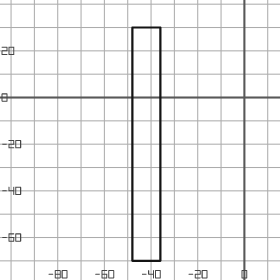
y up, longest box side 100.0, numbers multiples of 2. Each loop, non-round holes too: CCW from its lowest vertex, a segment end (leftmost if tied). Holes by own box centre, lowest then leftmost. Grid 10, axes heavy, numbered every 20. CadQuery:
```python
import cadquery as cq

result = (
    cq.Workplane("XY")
    .moveTo(-48.0, -70.0)
    .lineTo(-36.0, -70.0)
    .lineTo(-36.0, 30.0)
    .lineTo(-48.0, 30.0)
    .close()
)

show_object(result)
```